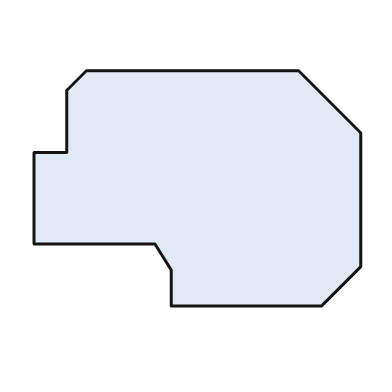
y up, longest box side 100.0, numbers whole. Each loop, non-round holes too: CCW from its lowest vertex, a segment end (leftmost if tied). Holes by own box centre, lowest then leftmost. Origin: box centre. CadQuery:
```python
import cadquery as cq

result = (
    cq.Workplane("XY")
    .moveTo(-8.0, -36.0)
    .lineTo(38.0, -36.0)
    .lineTo(50.0, -24.0)
    .lineTo(50.0, 17.0)
    .lineTo(31.0, 36.0)
    .lineTo(-34.0, 36.0)
    .lineTo(-40.0, 30.0)
    .lineTo(-40.0, 11.0)
    .lineTo(-50.0, 11.0)
    .lineTo(-50.0, -17.0)
    .lineTo(-13.0, -17.0)
    .lineTo(-8.0, -25.0)
    .close()
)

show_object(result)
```